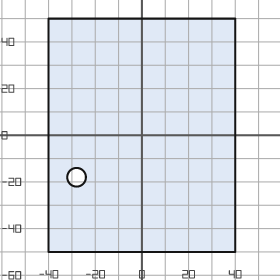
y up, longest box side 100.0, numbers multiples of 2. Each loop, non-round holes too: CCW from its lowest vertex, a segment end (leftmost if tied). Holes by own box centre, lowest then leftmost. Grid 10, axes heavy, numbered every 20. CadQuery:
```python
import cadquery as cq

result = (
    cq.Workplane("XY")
    .moveTo(-40.0, -50.0)
    .lineTo(40.0, -50.0)
    .lineTo(40.0, 50.0)
    .lineTo(-40.0, 50.0)
    .close()
    .moveTo(-28.0, -18.0)
    .circle(4.0)
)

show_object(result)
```